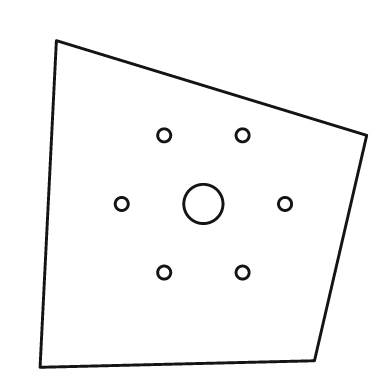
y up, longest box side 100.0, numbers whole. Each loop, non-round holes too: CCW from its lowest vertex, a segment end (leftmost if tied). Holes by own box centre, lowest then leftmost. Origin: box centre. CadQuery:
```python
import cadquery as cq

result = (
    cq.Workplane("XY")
    .moveTo(-50.0, -50.0)
    .lineTo(34.0, -48.0)
    .lineTo(50.0, 21.0)
    .lineTo(-45.0, 50.0)
    .close()
    .moveTo(-12.0, -21.0)
    .circle(2.0)
    .moveTo(12.0, -21.0)
    .circle(2.0)
    .moveTo(-25.0, 0.0)
    .circle(2.0)
    .moveTo(0.0, 0.0)
    .circle(6.0)
    .moveTo(25.0, 0.0)
    .circle(2.0)
    .moveTo(-12.0, 21.0)
    .circle(2.0)
    .moveTo(12.0, 21.0)
    .circle(2.0)
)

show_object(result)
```